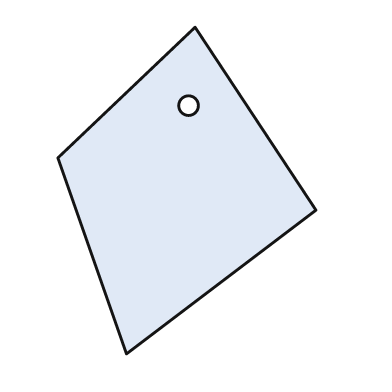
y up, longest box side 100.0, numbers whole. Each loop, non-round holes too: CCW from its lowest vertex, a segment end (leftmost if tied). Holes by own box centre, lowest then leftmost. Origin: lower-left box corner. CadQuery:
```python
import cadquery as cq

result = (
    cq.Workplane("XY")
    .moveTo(21.0, 0.0)
    .lineTo(79.0, 44.0)
    .lineTo(42.0, 100.0)
    .lineTo(0.0, 60.0)
    .close()
    .moveTo(40.0, 76.0)
    .circle(3.0)
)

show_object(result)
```